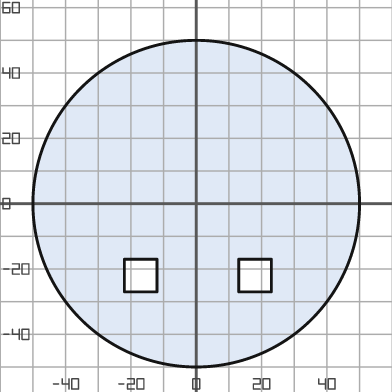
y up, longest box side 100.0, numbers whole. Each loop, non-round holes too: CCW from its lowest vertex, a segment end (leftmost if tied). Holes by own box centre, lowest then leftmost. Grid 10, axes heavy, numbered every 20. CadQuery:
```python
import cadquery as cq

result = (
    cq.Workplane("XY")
    .moveTo(0.0, 0.0)
    .circle(50.0)
    .moveTo(-22.0, -27.0)
    .lineTo(-12.0, -27.0)
    .lineTo(-12.0, -17.0)
    .lineTo(-22.0, -17.0)
    .close()
    .moveTo(13.0, -27.0)
    .lineTo(23.0, -27.0)
    .lineTo(23.0, -17.0)
    .lineTo(13.0, -17.0)
    .close()
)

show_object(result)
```